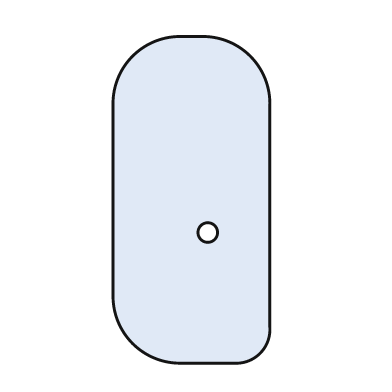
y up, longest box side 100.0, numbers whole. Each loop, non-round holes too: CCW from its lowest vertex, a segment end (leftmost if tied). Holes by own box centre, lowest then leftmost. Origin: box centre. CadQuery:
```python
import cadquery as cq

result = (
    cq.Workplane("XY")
    .moveTo(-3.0, -50.0)
    .lineTo(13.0, -50.0)
    .threePointArc((21.0, -47.0), (24.0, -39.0))
    .lineTo(24.0, 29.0)
    .threePointArc((18.0, 44.0), (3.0, 50.0))
    .lineTo(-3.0, 50.0)
    .threePointArc((-18.0, 44.0), (-24.0, 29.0))
    .lineTo(-24.0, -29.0)
    .threePointArc((-18.0, -44.0), (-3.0, -50.0))
    .close()
    .moveTo(5.0, -10.0)
    .circle(3.0)
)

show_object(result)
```